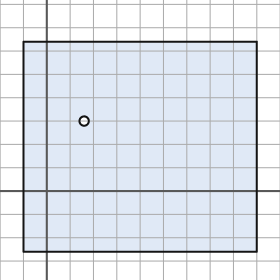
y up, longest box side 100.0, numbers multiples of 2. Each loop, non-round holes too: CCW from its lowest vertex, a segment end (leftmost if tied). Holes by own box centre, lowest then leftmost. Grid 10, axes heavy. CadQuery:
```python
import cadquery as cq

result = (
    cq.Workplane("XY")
    .moveTo(-10.0, -26.0)
    .lineTo(90.0, -26.0)
    .lineTo(90.0, 64.0)
    .lineTo(-10.0, 64.0)
    .close()
    .moveTo(16.0, 30.0)
    .circle(2.0)
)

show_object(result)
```